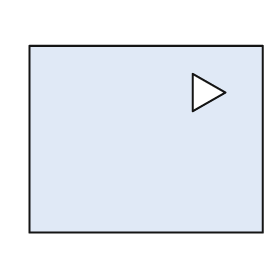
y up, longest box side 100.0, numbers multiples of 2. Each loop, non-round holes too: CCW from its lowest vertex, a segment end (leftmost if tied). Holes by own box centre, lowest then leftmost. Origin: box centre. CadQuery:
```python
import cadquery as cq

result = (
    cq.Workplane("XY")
    .moveTo(-50.0, -40.0)
    .lineTo(50.0, -40.0)
    .lineTo(50.0, 40.0)
    .lineTo(-50.0, 40.0)
    .close()
    .moveTo(20.0, 12.0)
    .lineTo(34.0, 20.0)
    .lineTo(20.0, 28.0)
    .close()
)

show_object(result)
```